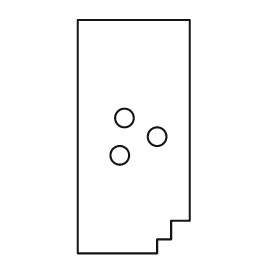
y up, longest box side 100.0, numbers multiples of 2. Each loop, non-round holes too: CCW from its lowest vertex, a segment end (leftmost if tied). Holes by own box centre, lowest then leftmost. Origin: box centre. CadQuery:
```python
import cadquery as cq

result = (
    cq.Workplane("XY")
    .moveTo(-24.0, -50.0)
    .lineTo(10.0, -50.0)
    .lineTo(10.0, -44.0)
    .lineTo(16.0, -44.0)
    .lineTo(16.0, -36.0)
    .lineTo(24.0, -36.0)
    .lineTo(24.0, 50.0)
    .lineTo(-24.0, 50.0)
    .close()
    .moveTo(-6.0, -8.0)
    .circle(4.0)
    .moveTo(10.0, 0.0)
    .circle(4.0)
    .moveTo(-4.0, 8.0)
    .circle(4.0)
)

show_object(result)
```